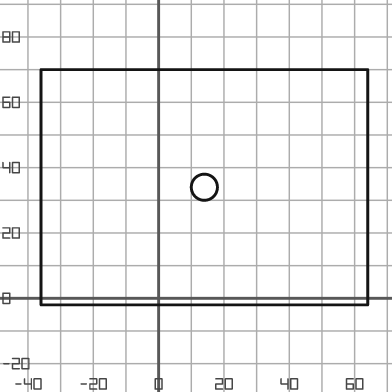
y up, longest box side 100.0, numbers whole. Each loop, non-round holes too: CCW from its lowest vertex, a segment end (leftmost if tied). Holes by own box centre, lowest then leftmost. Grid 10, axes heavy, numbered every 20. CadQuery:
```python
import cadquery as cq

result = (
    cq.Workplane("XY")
    .moveTo(-36.0, -2.0)
    .lineTo(64.0, -2.0)
    .lineTo(64.0, 70.0)
    .lineTo(-36.0, 70.0)
    .close()
    .moveTo(14.0, 34.0)
    .circle(4.0)
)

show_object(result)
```